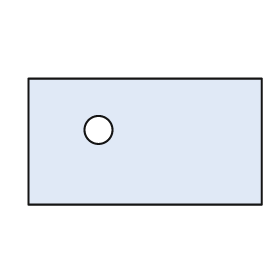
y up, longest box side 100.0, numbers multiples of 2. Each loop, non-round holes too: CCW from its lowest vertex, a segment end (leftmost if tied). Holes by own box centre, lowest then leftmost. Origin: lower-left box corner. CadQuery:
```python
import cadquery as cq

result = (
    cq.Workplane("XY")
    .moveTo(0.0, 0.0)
    .lineTo(100.0, 0.0)
    .lineTo(100.0, 54.0)
    .lineTo(0.0, 54.0)
    .close()
    .moveTo(30.0, 32.0)
    .circle(6.0)
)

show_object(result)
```